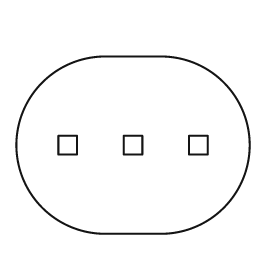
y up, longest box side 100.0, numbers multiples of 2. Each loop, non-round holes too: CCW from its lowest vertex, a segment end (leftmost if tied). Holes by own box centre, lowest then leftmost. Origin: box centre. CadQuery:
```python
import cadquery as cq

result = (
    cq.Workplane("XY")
    .moveTo(-12.0, -38.0)
    .lineTo(12.0, -38.0)
    .threePointArc((50.0, 0.0), (12.0, 38.0))
    .lineTo(-12.0, 38.0)
    .threePointArc((-50.0, 0.0), (-12.0, -38.0))
    .close()
    .moveTo(-32.0, -4.0)
    .lineTo(-24.0, -4.0)
    .lineTo(-24.0, 4.0)
    .lineTo(-32.0, 4.0)
    .close()
    .moveTo(-4.0, -4.0)
    .lineTo(4.0, -4.0)
    .lineTo(4.0, 4.0)
    .lineTo(-4.0, 4.0)
    .close()
    .moveTo(24.0, -4.0)
    .lineTo(32.0, -4.0)
    .lineTo(32.0, 4.0)
    .lineTo(24.0, 4.0)
    .close()
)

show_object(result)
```